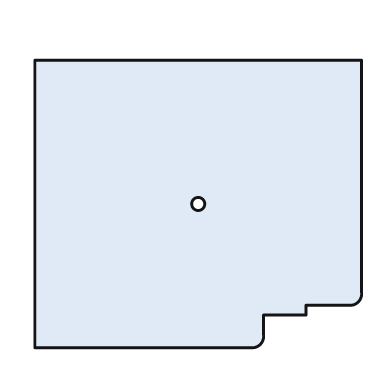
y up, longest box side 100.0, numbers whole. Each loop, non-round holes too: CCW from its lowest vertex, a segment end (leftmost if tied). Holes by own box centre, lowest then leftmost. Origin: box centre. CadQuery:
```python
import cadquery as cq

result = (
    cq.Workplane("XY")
    .moveTo(-50.0, -44.0)
    .lineTo(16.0, -44.0)
    .threePointArc((19.0, -43.0), (20.0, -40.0))
    .lineTo(20.0, -34.0)
    .lineTo(33.0, -34.0)
    .lineTo(33.0, -31.0)
    .lineTo(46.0, -31.0)
    .threePointArc((49.0, -30.0), (50.0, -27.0))
    .lineTo(50.0, 44.0)
    .lineTo(-50.0, 44.0)
    .close()
    .moveTo(0.0, 0.0)
    .circle(2.0)
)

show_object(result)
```